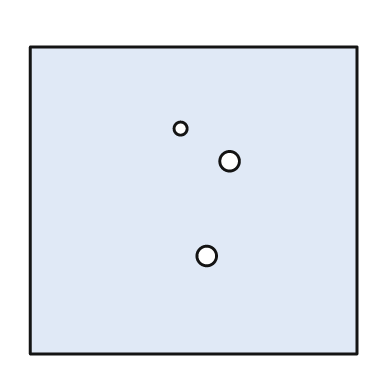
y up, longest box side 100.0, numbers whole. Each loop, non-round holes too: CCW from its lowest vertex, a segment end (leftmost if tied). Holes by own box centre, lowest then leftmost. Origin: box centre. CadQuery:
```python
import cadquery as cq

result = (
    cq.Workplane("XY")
    .moveTo(-50.0, -47.0)
    .lineTo(50.0, -47.0)
    .lineTo(50.0, 47.0)
    .lineTo(-50.0, 47.0)
    .close()
    .moveTo(4.0, -17.0)
    .circle(3.0)
    .moveTo(11.0, 12.0)
    .circle(3.0)
    .moveTo(-4.0, 22.0)
    .circle(2.0)
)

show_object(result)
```